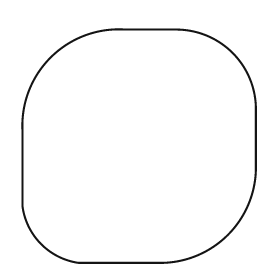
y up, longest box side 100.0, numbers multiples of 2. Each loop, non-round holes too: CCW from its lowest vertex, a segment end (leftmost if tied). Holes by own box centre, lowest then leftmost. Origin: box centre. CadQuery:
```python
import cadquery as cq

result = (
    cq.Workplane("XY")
    .moveTo(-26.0, -50.0)
    .lineTo(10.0, -50.0)
    .threePointArc((38.0, -38.0), (50.0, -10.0))
    .lineTo(50.0, 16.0)
    .threePointArc((40.0, 40.0), (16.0, 50.0))
    .lineTo(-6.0, 50.0)
    .threePointArc((-38.0, 38.0), (-50.0, 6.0))
    .lineTo(-50.0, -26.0)
    .threePointArc((-42.0, -42.0), (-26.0, -50.0))
    .close()
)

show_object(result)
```